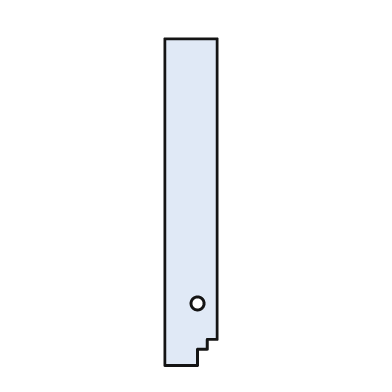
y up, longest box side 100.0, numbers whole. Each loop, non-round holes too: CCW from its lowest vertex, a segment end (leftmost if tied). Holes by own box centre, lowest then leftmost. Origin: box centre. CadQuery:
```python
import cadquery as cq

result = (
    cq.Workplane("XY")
    .moveTo(-8.0, -50.0)
    .lineTo(2.0, -50.0)
    .lineTo(2.0, -45.0)
    .lineTo(5.0, -45.0)
    .lineTo(5.0, -42.0)
    .lineTo(8.0, -42.0)
    .lineTo(8.0, 50.0)
    .lineTo(-8.0, 50.0)
    .close()
    .moveTo(2.0, -31.0)
    .circle(2.0)
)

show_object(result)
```